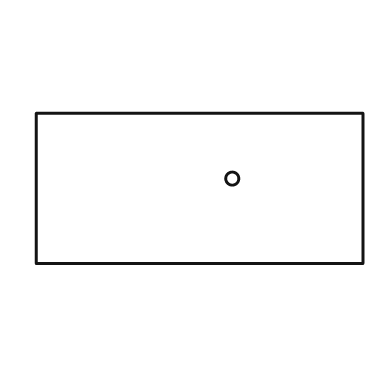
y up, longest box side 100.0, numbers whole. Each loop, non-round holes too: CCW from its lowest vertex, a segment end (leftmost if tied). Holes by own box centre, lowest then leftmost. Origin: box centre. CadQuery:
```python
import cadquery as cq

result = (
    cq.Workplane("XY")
    .moveTo(-50.0, -23.0)
    .lineTo(50.0, -23.0)
    .lineTo(50.0, 23.0)
    .lineTo(-50.0, 23.0)
    .close()
    .moveTo(10.0, 3.0)
    .circle(2.0)
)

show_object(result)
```